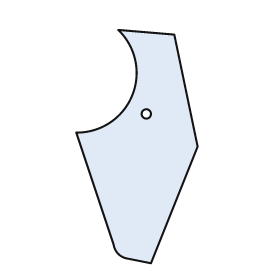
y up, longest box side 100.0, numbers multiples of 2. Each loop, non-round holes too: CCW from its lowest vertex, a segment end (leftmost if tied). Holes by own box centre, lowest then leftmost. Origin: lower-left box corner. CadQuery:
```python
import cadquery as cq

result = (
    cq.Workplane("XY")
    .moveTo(32.0, 0.0)
    .lineTo(52.0, 50.0)
    .lineTo(42.0, 98.0)
    .lineTo(18.0, 100.0)
    .threePointArc((24.0, 72.0), (0.0, 56.0))
    .lineTo(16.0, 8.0)
    .threePointArc((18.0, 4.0), (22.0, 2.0))
    .close()
    .moveTo(30.0, 64.0)
    .circle(2.0)
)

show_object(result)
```